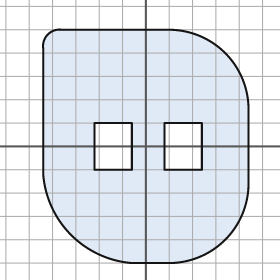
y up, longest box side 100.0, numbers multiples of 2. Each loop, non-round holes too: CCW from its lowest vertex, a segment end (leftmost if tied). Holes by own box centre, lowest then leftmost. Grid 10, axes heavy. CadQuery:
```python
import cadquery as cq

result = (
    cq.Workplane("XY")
    .moveTo(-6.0, -50.0)
    .lineTo(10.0, -50.0)
    .threePointArc((34.0, -40.0), (44.0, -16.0))
    .lineTo(44.0, 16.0)
    .threePointArc((34.0, 40.0), (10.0, 50.0))
    .lineTo(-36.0, 50.0)
    .threePointArc((-42.0, 48.0), (-44.0, 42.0))
    .lineTo(-44.0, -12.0)
    .threePointArc((-32.0, -38.0), (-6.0, -50.0))
    .close()
    .moveTo(-22.0, -10.0)
    .lineTo(-6.0, -10.0)
    .lineTo(-6.0, 10.0)
    .lineTo(-22.0, 10.0)
    .close()
    .moveTo(8.0, -10.0)
    .lineTo(24.0, -10.0)
    .lineTo(24.0, 10.0)
    .lineTo(8.0, 10.0)
    .close()
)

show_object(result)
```